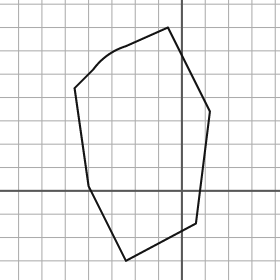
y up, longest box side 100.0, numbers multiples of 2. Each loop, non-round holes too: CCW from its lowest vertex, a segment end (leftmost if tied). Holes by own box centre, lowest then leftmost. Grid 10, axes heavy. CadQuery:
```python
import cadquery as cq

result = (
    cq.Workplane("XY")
    .moveTo(-24.0, -30.0)
    .lineTo(6.0, -14.0)
    .lineTo(12.0, 34.0)
    .lineTo(-6.0, 70.0)
    .lineTo(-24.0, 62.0)
    .threePointArc((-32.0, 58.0), (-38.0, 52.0))
    .lineTo(-46.0, 44.0)
    .lineTo(-40.0, 2.0)
    .close()
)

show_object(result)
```